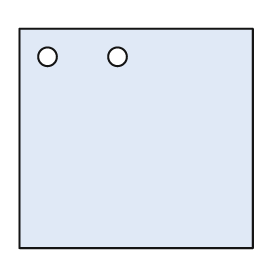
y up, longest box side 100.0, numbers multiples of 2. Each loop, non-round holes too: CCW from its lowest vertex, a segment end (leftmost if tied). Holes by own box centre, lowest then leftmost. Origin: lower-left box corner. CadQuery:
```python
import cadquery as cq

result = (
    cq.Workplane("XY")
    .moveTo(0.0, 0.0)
    .lineTo(100.0, 0.0)
    .lineTo(100.0, 94.0)
    .lineTo(0.0, 94.0)
    .close()
    .moveTo(12.0, 82.0)
    .circle(4.0)
    .moveTo(42.0, 82.0)
    .circle(4.0)
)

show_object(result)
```